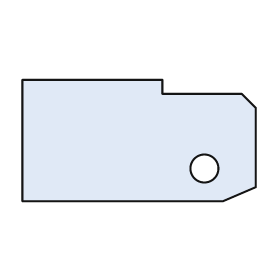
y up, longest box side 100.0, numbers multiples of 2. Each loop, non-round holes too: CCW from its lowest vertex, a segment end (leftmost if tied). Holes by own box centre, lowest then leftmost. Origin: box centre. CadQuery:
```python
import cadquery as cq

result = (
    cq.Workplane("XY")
    .moveTo(-50.0, -26.0)
    .lineTo(36.0, -26.0)
    .lineTo(50.0, -20.0)
    .lineTo(50.0, 14.0)
    .lineTo(44.0, 20.0)
    .lineTo(10.0, 20.0)
    .lineTo(10.0, 26.0)
    .lineTo(-50.0, 26.0)
    .close()
    .moveTo(28.0, -12.0)
    .circle(6.0)
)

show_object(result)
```